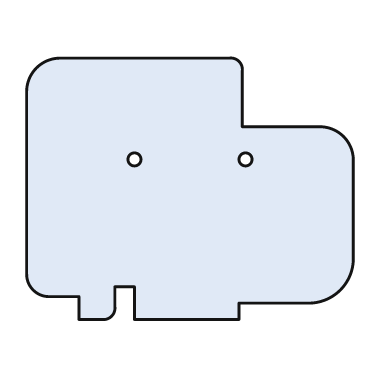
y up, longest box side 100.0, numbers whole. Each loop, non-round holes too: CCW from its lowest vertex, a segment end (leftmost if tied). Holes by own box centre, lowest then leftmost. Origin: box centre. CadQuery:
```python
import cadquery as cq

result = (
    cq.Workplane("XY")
    .moveTo(-34.0, -40.0)
    .lineTo(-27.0, -40.0)
    .threePointArc((-24.0, -39.0), (-23.0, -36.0))
    .lineTo(-23.0, -30.0)
    .lineTo(-17.0, -30.0)
    .lineTo(-17.0, -40.0)
    .lineTo(15.0, -40.0)
    .lineTo(15.0, -35.0)
    .lineTo(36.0, -35.0)
    .threePointArc((46.0, -31.0), (50.0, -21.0))
    .lineTo(50.0, 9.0)
    .threePointArc((47.0, 16.0), (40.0, 19.0))
    .lineTo(16.0, 19.0)
    .lineTo(16.0, 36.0)
    .threePointArc((15.0, 39.0), (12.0, 40.0))
    .lineTo(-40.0, 40.0)
    .threePointArc((-47.0, 37.0), (-50.0, 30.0))
    .lineTo(-50.0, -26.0)
    .threePointArc((-48.0, -31.0), (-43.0, -33.0))
    .lineTo(-34.0, -33.0)
    .close()
    .moveTo(-17.0, 9.0)
    .circle(2.0)
    .moveTo(17.0, 9.0)
    .circle(2.0)
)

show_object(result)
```